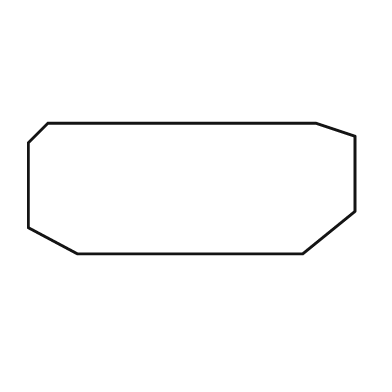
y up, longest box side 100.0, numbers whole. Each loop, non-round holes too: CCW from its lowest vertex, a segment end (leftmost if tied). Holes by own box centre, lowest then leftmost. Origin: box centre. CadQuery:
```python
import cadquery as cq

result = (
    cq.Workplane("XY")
    .moveTo(-35.0, -20.0)
    .lineTo(34.0, -20.0)
    .lineTo(50.0, -7.0)
    .lineTo(50.0, 16.0)
    .lineTo(38.0, 20.0)
    .lineTo(-44.0, 20.0)
    .lineTo(-50.0, 14.0)
    .lineTo(-50.0, -12.0)
    .close()
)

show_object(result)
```